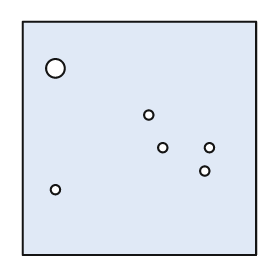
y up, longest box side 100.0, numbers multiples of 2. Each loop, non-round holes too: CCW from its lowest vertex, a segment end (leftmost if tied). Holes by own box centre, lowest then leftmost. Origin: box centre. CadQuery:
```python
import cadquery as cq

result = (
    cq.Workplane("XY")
    .moveTo(-50.0, -50.0)
    .lineTo(50.0, -50.0)
    .lineTo(50.0, 50.0)
    .lineTo(-50.0, 50.0)
    .close()
    .moveTo(-36.0, -22.0)
    .circle(2.0)
    .moveTo(28.0, -14.0)
    .circle(2.0)
    .moveTo(10.0, -4.0)
    .circle(2.0)
    .moveTo(30.0, -4.0)
    .circle(2.0)
    .moveTo(4.0, 10.0)
    .circle(2.0)
    .moveTo(-36.0, 30.0)
    .circle(4.0)
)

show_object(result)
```